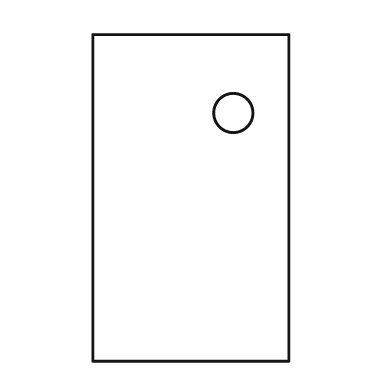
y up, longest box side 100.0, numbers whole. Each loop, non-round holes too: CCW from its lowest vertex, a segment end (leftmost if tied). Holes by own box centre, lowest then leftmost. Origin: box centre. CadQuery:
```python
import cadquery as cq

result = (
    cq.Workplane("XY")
    .moveTo(-30.0, -50.0)
    .lineTo(30.0, -50.0)
    .lineTo(30.0, 50.0)
    .lineTo(-30.0, 50.0)
    .close()
    .moveTo(13.0, 26.0)
    .circle(6.0)
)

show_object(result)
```